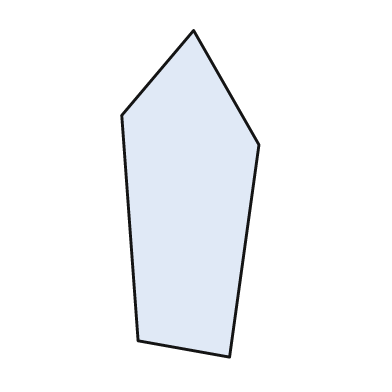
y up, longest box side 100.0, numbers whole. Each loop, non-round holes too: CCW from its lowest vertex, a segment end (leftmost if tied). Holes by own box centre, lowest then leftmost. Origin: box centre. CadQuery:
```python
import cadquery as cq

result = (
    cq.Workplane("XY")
    .moveTo(12.0, -50.0)
    .lineTo(21.0, 15.0)
    .lineTo(1.0, 50.0)
    .lineTo(-21.0, 24.0)
    .lineTo(-16.0, -45.0)
    .close()
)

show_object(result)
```